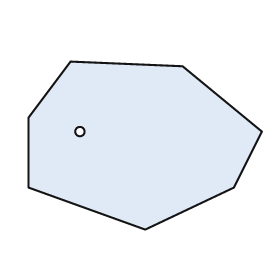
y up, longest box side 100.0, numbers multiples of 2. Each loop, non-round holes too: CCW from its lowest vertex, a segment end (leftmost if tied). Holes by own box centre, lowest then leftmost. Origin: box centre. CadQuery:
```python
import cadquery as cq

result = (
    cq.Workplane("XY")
    .moveTo(0.0, -36.0)
    .lineTo(38.0, -18.0)
    .lineTo(50.0, 6.0)
    .lineTo(16.0, 34.0)
    .lineTo(-32.0, 36.0)
    .lineTo(-50.0, 12.0)
    .lineTo(-50.0, -18.0)
    .close()
    .moveTo(-28.0, 6.0)
    .circle(2.0)
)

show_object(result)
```